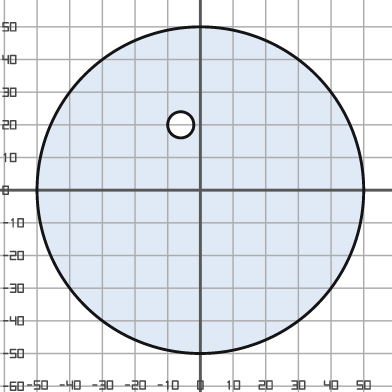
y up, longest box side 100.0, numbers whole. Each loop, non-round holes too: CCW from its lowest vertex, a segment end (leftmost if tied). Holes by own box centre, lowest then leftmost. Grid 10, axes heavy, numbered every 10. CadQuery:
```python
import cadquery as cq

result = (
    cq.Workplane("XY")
    .moveTo(0.0, 0.0)
    .circle(50.0)
    .moveTo(-6.0, 20.0)
    .circle(4.0)
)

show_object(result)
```